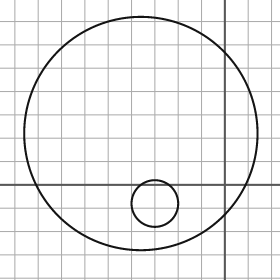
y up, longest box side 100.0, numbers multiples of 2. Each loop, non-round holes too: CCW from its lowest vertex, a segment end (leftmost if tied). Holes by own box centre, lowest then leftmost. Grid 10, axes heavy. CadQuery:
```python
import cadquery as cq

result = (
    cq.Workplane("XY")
    .moveTo(-36.0, 22.0)
    .circle(50.0)
    .moveTo(-30.0, -8.0)
    .circle(10.0)
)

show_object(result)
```